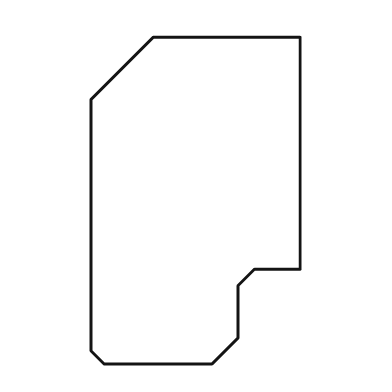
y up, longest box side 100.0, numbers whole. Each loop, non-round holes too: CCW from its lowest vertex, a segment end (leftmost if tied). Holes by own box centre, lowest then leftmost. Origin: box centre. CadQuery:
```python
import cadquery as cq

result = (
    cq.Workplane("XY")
    .moveTo(-28.0, -50.0)
    .lineTo(5.0, -50.0)
    .lineTo(13.0, -42.0)
    .lineTo(13.0, -26.0)
    .lineTo(18.0, -21.0)
    .lineTo(32.0, -21.0)
    .lineTo(32.0, 50.0)
    .lineTo(-13.0, 50.0)
    .lineTo(-32.0, 31.0)
    .lineTo(-32.0, -46.0)
    .close()
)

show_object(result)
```